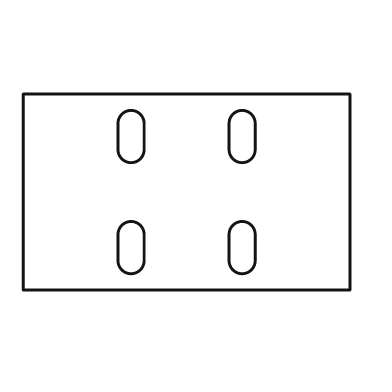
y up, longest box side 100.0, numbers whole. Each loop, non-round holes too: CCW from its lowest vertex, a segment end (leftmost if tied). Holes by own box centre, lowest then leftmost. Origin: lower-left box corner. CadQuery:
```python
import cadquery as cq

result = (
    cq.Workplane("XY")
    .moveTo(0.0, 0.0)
    .lineTo(100.0, 0.0)
    .lineTo(100.0, 60.0)
    .lineTo(0.0, 60.0)
    .close()
    .moveTo(29.0, 9.0)
    .threePointArc((33.0, 5.0), (37.0, 9.0))
    .lineTo(37.0, 17.0)
    .threePointArc((33.0, 21.0), (29.0, 17.0))
    .close()
    .moveTo(63.0, 9.0)
    .threePointArc((67.0, 5.0), (71.0, 9.0))
    .lineTo(71.0, 17.0)
    .threePointArc((67.0, 21.0), (63.0, 17.0))
    .close()
    .moveTo(29.0, 43.0)
    .threePointArc((33.0, 39.0), (37.0, 43.0))
    .lineTo(37.0, 51.0)
    .threePointArc((33.0, 55.0), (29.0, 51.0))
    .close()
    .moveTo(63.0, 43.0)
    .threePointArc((67.0, 39.0), (71.0, 43.0))
    .lineTo(71.0, 51.0)
    .threePointArc((67.0, 55.0), (63.0, 51.0))
    .close()
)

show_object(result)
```